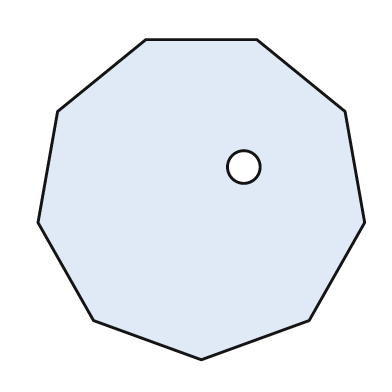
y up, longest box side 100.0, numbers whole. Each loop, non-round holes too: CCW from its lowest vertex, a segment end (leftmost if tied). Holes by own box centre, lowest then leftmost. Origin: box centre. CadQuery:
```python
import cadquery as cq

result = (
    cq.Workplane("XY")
    .moveTo(0.0, -49.0)
    .lineTo(33.0, -37.0)
    .lineTo(50.0, -7.0)
    .lineTo(44.0, 27.0)
    .lineTo(17.0, 49.0)
    .lineTo(-17.0, 49.0)
    .lineTo(-44.0, 27.0)
    .lineTo(-50.0, -7.0)
    .lineTo(-33.0, -37.0)
    .close()
    .moveTo(13.0, 10.0)
    .circle(5.0)
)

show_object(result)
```